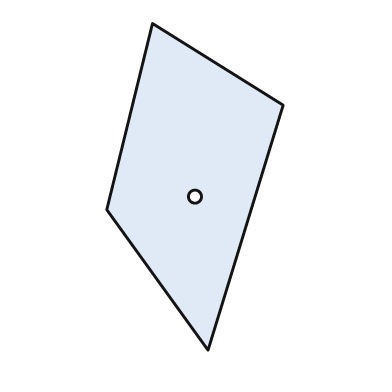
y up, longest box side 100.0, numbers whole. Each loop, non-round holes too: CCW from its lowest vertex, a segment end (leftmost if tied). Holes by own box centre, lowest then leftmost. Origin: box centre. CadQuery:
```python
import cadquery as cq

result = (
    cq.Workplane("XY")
    .moveTo(4.0, -50.0)
    .lineTo(27.0, 25.0)
    .lineTo(-13.0, 50.0)
    .lineTo(-27.0, -7.0)
    .close()
    .moveTo(0.0, -3.0)
    .circle(2.0)
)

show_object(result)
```